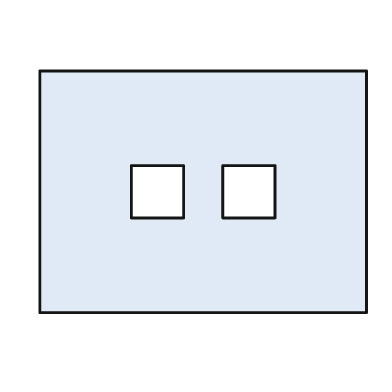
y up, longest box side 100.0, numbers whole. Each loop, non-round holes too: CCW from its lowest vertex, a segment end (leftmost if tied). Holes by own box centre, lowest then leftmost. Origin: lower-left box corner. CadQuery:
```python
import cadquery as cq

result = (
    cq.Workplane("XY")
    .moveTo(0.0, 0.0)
    .lineTo(100.0, 0.0)
    .lineTo(100.0, 74.0)
    .lineTo(0.0, 74.0)
    .close()
    .moveTo(28.0, 29.0)
    .lineTo(44.0, 29.0)
    .lineTo(44.0, 45.0)
    .lineTo(28.0, 45.0)
    .close()
    .moveTo(56.0, 29.0)
    .lineTo(72.0, 29.0)
    .lineTo(72.0, 45.0)
    .lineTo(56.0, 45.0)
    .close()
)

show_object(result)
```